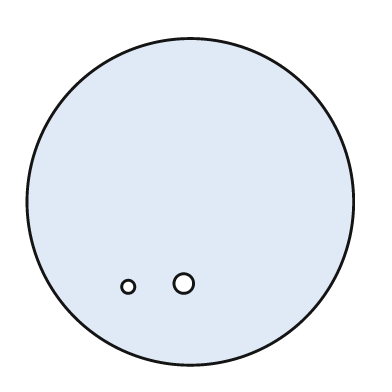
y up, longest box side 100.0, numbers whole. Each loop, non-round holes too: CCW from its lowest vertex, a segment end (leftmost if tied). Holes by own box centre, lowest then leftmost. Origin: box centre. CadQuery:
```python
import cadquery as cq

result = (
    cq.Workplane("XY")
    .moveTo(0.0, 0.0)
    .circle(50.0)
    .moveTo(-19.0, -26.0)
    .circle(2.0)
    .moveTo(-2.0, -25.0)
    .circle(3.0)
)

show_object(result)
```